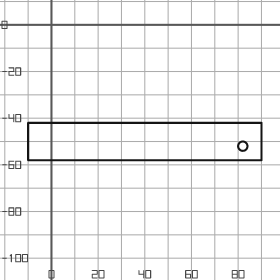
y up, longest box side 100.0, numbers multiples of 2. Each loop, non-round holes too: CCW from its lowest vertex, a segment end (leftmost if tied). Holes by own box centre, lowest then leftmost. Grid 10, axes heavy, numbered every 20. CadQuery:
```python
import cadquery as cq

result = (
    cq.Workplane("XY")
    .moveTo(-10.0, -58.0)
    .lineTo(90.0, -58.0)
    .lineTo(90.0, -42.0)
    .lineTo(-10.0, -42.0)
    .close()
    .moveTo(82.0, -52.0)
    .circle(2.0)
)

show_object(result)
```